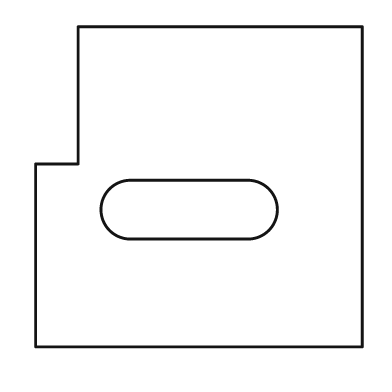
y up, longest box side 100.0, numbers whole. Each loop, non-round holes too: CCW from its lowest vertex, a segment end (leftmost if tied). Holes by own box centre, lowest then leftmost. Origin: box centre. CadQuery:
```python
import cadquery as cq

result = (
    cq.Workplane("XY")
    .moveTo(-50.0, -49.0)
    .lineTo(50.0, -49.0)
    .lineTo(50.0, 49.0)
    .lineTo(-37.0, 49.0)
    .lineTo(-37.0, 7.0)
    .lineTo(-50.0, 7.0)
    .close()
    .moveTo(-21.0, -16.0)
    .lineTo(15.0, -16.0)
    .threePointArc((24.0, -7.0), (15.0, 2.0))
    .lineTo(-21.0, 2.0)
    .threePointArc((-30.0, -7.0), (-21.0, -16.0))
    .close()
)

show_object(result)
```